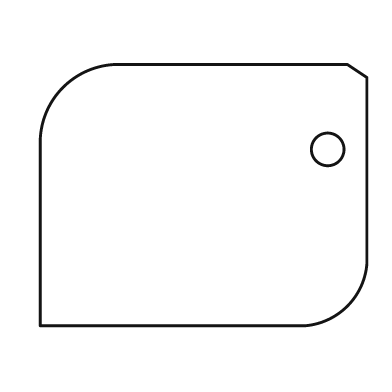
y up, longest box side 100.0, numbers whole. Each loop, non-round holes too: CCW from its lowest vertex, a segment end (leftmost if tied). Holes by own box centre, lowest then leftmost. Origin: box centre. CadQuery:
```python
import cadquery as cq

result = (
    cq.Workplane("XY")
    .moveTo(-50.0, -40.0)
    .lineTo(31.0, -40.0)
    .threePointArc((44.0, -34.0), (50.0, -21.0))
    .lineTo(50.0, 36.0)
    .lineTo(44.0, 40.0)
    .lineTo(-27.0, 40.0)
    .threePointArc((-43.0, 33.0), (-50.0, 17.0))
    .close()
    .moveTo(38.0, 14.0)
    .circle(5.0)
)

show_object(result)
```